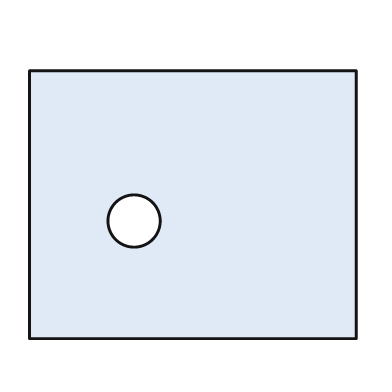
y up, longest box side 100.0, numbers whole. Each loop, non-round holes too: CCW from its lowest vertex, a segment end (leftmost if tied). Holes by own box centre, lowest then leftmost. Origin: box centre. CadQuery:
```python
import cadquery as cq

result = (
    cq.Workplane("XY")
    .moveTo(-50.0, -41.0)
    .lineTo(50.0, -41.0)
    .lineTo(50.0, 41.0)
    .lineTo(-50.0, 41.0)
    .close()
    .moveTo(-18.0, -5.0)
    .circle(8.0)
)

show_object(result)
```